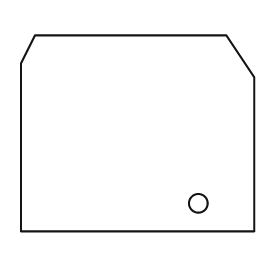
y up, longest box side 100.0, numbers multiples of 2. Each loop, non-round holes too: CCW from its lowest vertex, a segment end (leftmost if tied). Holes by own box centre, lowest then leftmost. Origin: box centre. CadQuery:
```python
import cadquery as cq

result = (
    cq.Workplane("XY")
    .moveTo(-50.0, -42.0)
    .lineTo(50.0, -42.0)
    .lineTo(50.0, 24.0)
    .lineTo(38.0, 42.0)
    .lineTo(-44.0, 42.0)
    .lineTo(-50.0, 30.0)
    .close()
    .moveTo(26.0, -30.0)
    .circle(4.0)
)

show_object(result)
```